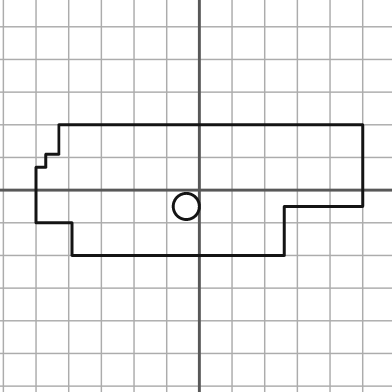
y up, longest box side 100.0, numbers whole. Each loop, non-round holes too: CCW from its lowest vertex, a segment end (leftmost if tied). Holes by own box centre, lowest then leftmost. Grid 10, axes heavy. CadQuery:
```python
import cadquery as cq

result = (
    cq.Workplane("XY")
    .moveTo(-39.0, -20.0)
    .lineTo(26.0, -20.0)
    .lineTo(26.0, -5.0)
    .lineTo(50.0, -5.0)
    .lineTo(50.0, 20.0)
    .lineTo(-43.0, 20.0)
    .lineTo(-43.0, 11.0)
    .lineTo(-47.0, 11.0)
    .lineTo(-47.0, 7.0)
    .lineTo(-50.0, 7.0)
    .lineTo(-50.0, -10.0)
    .lineTo(-39.0, -10.0)
    .close()
    .moveTo(-4.0, -5.0)
    .circle(4.0)
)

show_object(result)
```